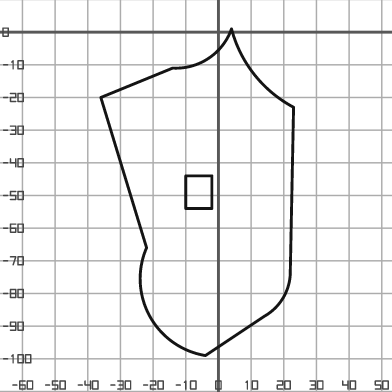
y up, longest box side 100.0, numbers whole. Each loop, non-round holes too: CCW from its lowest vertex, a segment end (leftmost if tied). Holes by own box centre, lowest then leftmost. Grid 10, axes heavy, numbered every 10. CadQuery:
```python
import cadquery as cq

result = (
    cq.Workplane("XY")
    .moveTo(-4.0, -99.0)
    .lineTo(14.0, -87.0)
    .threePointArc((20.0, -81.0), (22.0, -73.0))
    .lineTo(23.0, -23.0)
    .threePointArc((11.0, -13.0), (4.0, 1.0))
    .threePointArc((-3.0, -8.0), (-14.0, -11.0))
    .lineTo(-36.0, -20.0)
    .lineTo(-22.0, -66.0)
    .threePointArc((-21.0, -87.0), (-4.0, -99.0))
    .close()
    .moveTo(-10.0, -54.0)
    .lineTo(-2.0, -54.0)
    .lineTo(-2.0, -44.0)
    .lineTo(-10.0, -44.0)
    .close()
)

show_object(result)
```